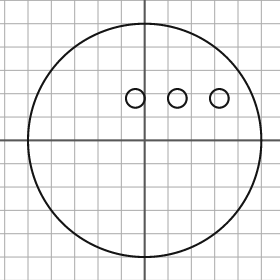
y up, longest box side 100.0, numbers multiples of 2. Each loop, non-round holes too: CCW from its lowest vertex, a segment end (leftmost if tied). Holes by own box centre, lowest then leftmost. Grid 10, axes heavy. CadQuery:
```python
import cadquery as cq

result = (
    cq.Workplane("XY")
    .moveTo(0.0, 0.0)
    .circle(50.0)
    .moveTo(-4.0, 18.0)
    .circle(4.0)
    .moveTo(14.0, 18.0)
    .circle(4.0)
    .moveTo(32.0, 18.0)
    .circle(4.0)
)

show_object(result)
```